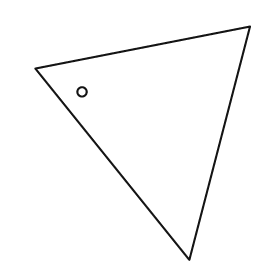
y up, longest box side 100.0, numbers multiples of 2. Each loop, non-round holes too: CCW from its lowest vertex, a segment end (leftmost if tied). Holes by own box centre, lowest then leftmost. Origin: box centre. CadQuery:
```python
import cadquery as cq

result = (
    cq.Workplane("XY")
    .moveTo(20.0, -50.0)
    .lineTo(46.0, 50.0)
    .lineTo(-46.0, 32.0)
    .close()
    .moveTo(-26.0, 22.0)
    .circle(2.0)
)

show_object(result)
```